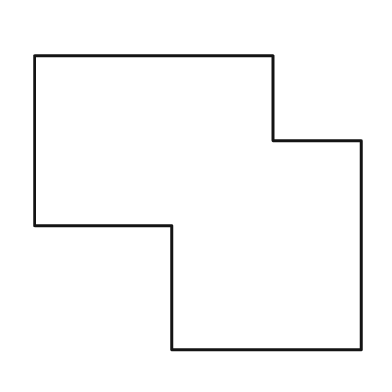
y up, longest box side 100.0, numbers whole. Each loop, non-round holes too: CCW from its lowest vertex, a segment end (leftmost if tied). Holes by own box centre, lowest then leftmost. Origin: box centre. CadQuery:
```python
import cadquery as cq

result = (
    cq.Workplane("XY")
    .moveTo(-8.0, -45.0)
    .lineTo(50.0, -45.0)
    .lineTo(50.0, 19.0)
    .lineTo(23.0, 19.0)
    .lineTo(23.0, 45.0)
    .lineTo(-50.0, 45.0)
    .lineTo(-50.0, -7.0)
    .lineTo(-8.0, -7.0)
    .close()
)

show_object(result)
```